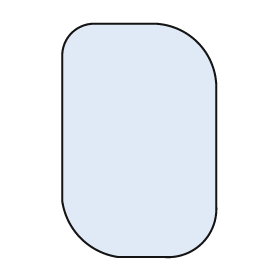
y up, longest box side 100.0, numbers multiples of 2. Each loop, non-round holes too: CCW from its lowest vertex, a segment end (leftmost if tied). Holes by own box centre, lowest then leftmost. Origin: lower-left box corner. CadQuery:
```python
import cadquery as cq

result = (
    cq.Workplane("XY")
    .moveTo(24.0, 0.0)
    .lineTo(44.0, 0.0)
    .threePointArc((60.0, 6.0), (66.0, 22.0))
    .lineTo(66.0, 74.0)
    .threePointArc((58.0, 92.0), (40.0, 100.0))
    .lineTo(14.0, 100.0)
    .threePointArc((4.0, 96.0), (0.0, 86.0))
    .lineTo(0.0, 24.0)
    .threePointArc((8.0, 8.0), (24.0, 0.0))
    .close()
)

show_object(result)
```